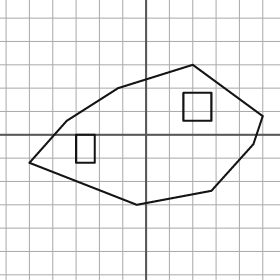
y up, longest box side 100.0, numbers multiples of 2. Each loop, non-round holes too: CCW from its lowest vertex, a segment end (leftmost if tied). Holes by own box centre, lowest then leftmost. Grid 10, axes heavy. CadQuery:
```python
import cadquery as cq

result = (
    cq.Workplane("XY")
    .moveTo(-4.0, -30.0)
    .lineTo(28.0, -24.0)
    .lineTo(46.0, -4.0)
    .lineTo(50.0, 8.0)
    .lineTo(20.0, 30.0)
    .lineTo(-12.0, 20.0)
    .lineTo(-34.0, 6.0)
    .lineTo(-50.0, -12.0)
    .close()
    .moveTo(-30.0, -12.0)
    .lineTo(-22.0, -12.0)
    .lineTo(-22.0, 0.0)
    .lineTo(-30.0, 0.0)
    .close()
    .moveTo(16.0, 6.0)
    .lineTo(28.0, 6.0)
    .lineTo(28.0, 18.0)
    .lineTo(16.0, 18.0)
    .close()
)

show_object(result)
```